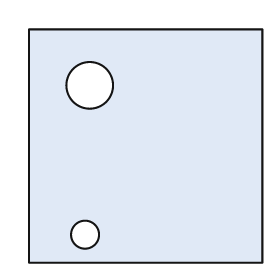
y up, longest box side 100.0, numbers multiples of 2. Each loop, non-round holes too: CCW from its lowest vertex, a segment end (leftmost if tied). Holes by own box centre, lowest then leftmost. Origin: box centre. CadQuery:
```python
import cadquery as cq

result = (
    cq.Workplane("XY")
    .moveTo(-50.0, -50.0)
    .lineTo(50.0, -50.0)
    .lineTo(50.0, 50.0)
    .lineTo(-50.0, 50.0)
    .close()
    .moveTo(-26.0, -38.0)
    .circle(6.0)
    .moveTo(-24.0, 26.0)
    .circle(10.0)
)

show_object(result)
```